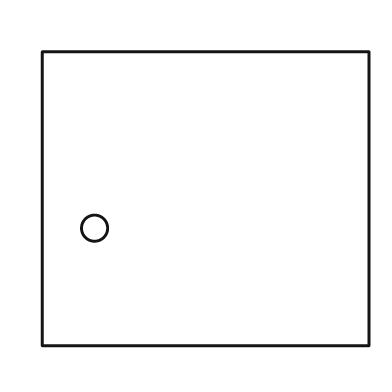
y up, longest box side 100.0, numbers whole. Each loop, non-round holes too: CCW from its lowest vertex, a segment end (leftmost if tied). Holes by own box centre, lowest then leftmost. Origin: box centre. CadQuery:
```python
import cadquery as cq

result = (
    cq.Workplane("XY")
    .moveTo(-50.0, -45.0)
    .lineTo(50.0, -45.0)
    .lineTo(50.0, 45.0)
    .lineTo(-50.0, 45.0)
    .close()
    .moveTo(-34.0, -9.0)
    .circle(4.0)
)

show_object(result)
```